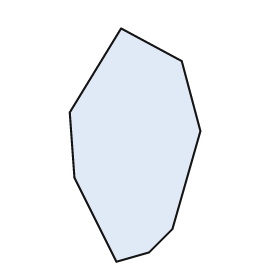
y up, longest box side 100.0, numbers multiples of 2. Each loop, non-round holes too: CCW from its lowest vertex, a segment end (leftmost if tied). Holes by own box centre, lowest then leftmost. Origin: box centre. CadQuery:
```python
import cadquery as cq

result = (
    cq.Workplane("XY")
    .moveTo(-8.0, -50.0)
    .lineTo(6.0, -46.0)
    .lineTo(16.0, -36.0)
    .lineTo(28.0, 6.0)
    .lineTo(20.0, 36.0)
    .lineTo(-6.0, 50.0)
    .lineTo(-28.0, 14.0)
    .lineTo(-26.0, -14.0)
    .close()
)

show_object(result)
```